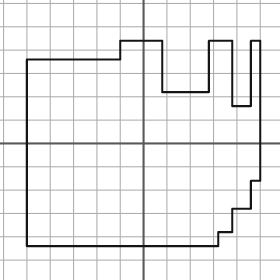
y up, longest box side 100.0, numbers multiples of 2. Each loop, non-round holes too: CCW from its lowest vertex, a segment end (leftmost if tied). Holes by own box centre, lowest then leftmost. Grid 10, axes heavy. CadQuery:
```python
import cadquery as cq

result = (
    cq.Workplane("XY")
    .moveTo(-50.0, -44.0)
    .lineTo(32.0, -44.0)
    .lineTo(32.0, -38.0)
    .lineTo(38.0, -38.0)
    .lineTo(38.0, -28.0)
    .lineTo(46.0, -28.0)
    .lineTo(46.0, -16.0)
    .lineTo(50.0, -16.0)
    .lineTo(50.0, 44.0)
    .lineTo(46.0, 44.0)
    .lineTo(46.0, 16.0)
    .lineTo(38.0, 16.0)
    .lineTo(38.0, 44.0)
    .lineTo(28.0, 44.0)
    .lineTo(28.0, 22.0)
    .lineTo(8.0, 22.0)
    .lineTo(8.0, 44.0)
    .lineTo(-10.0, 44.0)
    .lineTo(-10.0, 36.0)
    .lineTo(-50.0, 36.0)
    .close()
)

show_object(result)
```